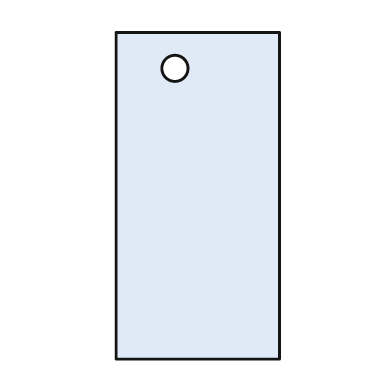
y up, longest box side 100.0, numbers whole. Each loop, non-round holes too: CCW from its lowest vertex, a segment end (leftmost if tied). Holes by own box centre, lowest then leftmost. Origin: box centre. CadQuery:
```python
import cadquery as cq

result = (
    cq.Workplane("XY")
    .moveTo(-25.0, -50.0)
    .lineTo(25.0, -50.0)
    .lineTo(25.0, 50.0)
    .lineTo(-25.0, 50.0)
    .close()
    .moveTo(-7.0, 39.0)
    .circle(4.0)
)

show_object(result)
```